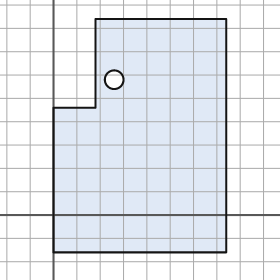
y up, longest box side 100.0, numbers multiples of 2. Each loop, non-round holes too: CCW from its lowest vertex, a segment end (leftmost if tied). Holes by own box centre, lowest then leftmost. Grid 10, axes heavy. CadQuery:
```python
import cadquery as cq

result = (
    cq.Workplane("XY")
    .moveTo(0.0, -16.0)
    .lineTo(74.0, -16.0)
    .lineTo(74.0, 84.0)
    .lineTo(18.0, 84.0)
    .lineTo(18.0, 46.0)
    .lineTo(0.0, 46.0)
    .close()
    .moveTo(26.0, 58.0)
    .circle(4.0)
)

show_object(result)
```